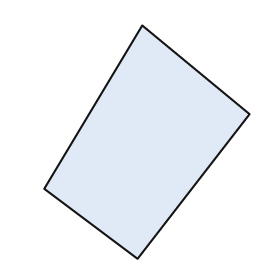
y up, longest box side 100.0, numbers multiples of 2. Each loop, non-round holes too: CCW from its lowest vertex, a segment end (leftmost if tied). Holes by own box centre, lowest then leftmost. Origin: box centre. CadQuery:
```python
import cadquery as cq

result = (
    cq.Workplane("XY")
    .moveTo(-4.0, -50.0)
    .lineTo(44.0, 12.0)
    .lineTo(-2.0, 50.0)
    .lineTo(-44.0, -20.0)
    .close()
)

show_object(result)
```